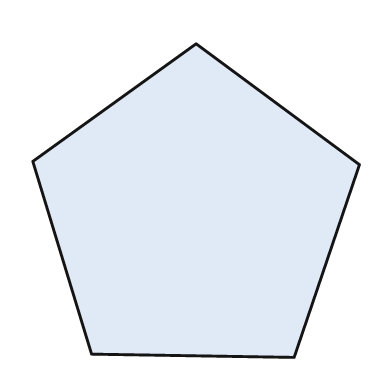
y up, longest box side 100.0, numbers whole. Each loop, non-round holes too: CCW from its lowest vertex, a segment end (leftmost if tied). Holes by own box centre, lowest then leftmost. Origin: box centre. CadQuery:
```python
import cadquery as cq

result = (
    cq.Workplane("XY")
    .moveTo(30.0, -48.0)
    .lineTo(50.0, 11.0)
    .lineTo(0.0, 48.0)
    .lineTo(-50.0, 12.0)
    .lineTo(-32.0, -47.0)
    .close()
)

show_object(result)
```